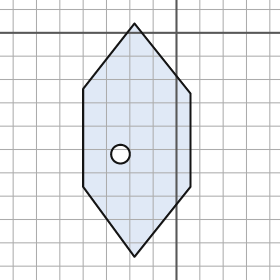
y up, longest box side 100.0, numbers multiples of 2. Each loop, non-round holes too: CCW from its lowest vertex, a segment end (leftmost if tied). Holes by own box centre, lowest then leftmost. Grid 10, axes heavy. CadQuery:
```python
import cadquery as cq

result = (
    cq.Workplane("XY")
    .moveTo(-18.0, -96.0)
    .lineTo(6.0, -66.0)
    .lineTo(6.0, -26.0)
    .lineTo(-18.0, 4.0)
    .lineTo(-40.0, -24.0)
    .lineTo(-40.0, -66.0)
    .close()
    .moveTo(-24.0, -52.0)
    .circle(4.0)
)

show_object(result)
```